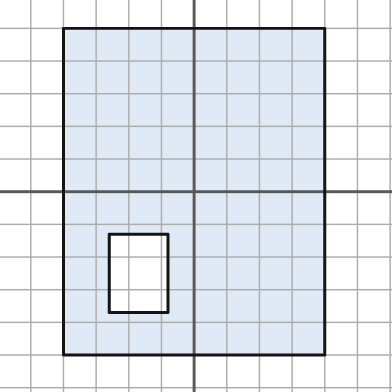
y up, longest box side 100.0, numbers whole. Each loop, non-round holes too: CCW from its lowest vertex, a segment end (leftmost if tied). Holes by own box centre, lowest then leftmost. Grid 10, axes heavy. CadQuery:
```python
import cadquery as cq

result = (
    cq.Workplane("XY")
    .moveTo(-40.0, -50.0)
    .lineTo(40.0, -50.0)
    .lineTo(40.0, 50.0)
    .lineTo(-40.0, 50.0)
    .close()
    .moveTo(-26.0, -37.0)
    .lineTo(-8.0, -37.0)
    .lineTo(-8.0, -13.0)
    .lineTo(-26.0, -13.0)
    .close()
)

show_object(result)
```